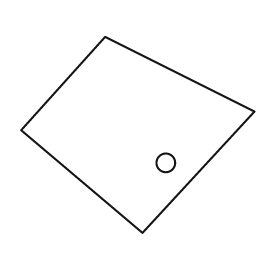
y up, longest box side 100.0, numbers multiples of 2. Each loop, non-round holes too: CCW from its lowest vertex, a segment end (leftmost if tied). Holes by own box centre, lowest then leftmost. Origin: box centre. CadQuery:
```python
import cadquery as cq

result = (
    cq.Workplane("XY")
    .moveTo(2.0, -42.0)
    .lineTo(50.0, 10.0)
    .lineTo(-14.0, 42.0)
    .lineTo(-50.0, 2.0)
    .close()
    .moveTo(12.0, -12.0)
    .circle(4.0)
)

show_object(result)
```